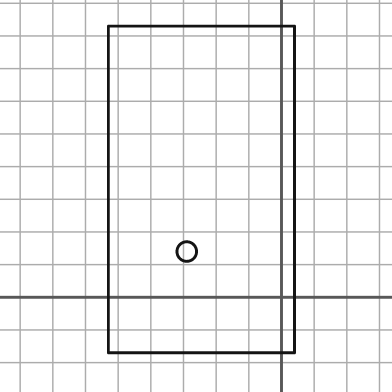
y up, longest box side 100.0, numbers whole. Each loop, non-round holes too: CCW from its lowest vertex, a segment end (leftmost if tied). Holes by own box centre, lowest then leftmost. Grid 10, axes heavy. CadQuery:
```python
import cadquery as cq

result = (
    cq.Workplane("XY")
    .moveTo(-53.0, -17.0)
    .lineTo(4.0, -17.0)
    .lineTo(4.0, 83.0)
    .lineTo(-53.0, 83.0)
    .close()
    .moveTo(-29.0, 14.0)
    .circle(3.0)
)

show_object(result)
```